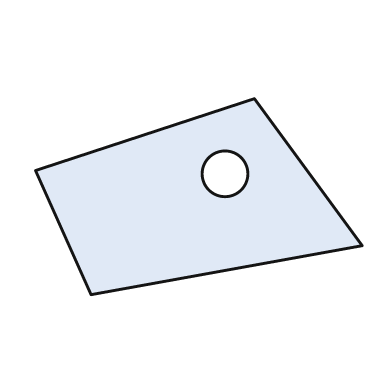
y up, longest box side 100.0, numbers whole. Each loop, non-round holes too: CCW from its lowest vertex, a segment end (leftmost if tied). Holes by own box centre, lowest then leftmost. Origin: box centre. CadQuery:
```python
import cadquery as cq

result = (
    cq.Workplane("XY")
    .moveTo(-33.0, -30.0)
    .lineTo(50.0, -15.0)
    .lineTo(17.0, 30.0)
    .lineTo(-50.0, 8.0)
    .close()
    .moveTo(8.0, 7.0)
    .circle(7.0)
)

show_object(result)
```